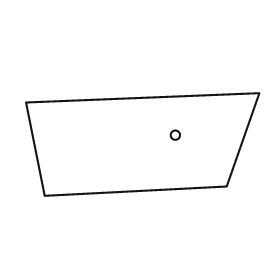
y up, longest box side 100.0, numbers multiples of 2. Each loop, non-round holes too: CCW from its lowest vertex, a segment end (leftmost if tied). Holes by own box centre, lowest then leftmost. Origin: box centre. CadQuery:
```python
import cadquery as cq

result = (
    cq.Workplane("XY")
    .moveTo(-42.0, -22.0)
    .lineTo(36.0, -18.0)
    .lineTo(50.0, 22.0)
    .lineTo(-50.0, 18.0)
    .close()
    .moveTo(14.0, 4.0)
    .circle(2.0)
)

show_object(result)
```